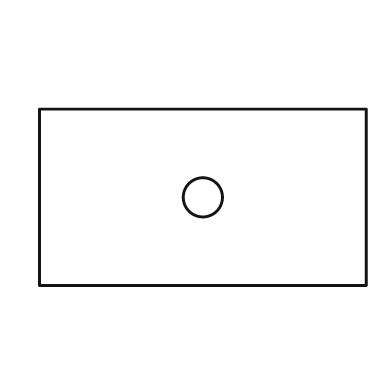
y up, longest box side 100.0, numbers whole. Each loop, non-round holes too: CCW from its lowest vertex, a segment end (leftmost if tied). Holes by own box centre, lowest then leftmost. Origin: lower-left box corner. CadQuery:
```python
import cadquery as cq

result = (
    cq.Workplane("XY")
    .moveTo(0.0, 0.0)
    .lineTo(100.0, 0.0)
    .lineTo(100.0, 54.0)
    .lineTo(0.0, 54.0)
    .close()
    .moveTo(50.0, 27.0)
    .circle(6.0)
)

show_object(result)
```